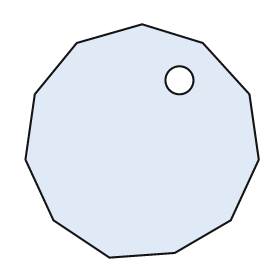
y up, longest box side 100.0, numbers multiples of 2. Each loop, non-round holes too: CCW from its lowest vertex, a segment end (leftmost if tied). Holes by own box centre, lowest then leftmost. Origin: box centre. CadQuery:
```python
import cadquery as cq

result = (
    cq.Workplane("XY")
    .moveTo(-14.0, -50.0)
    .lineTo(14.0, -48.0)
    .lineTo(38.0, -34.0)
    .lineTo(50.0, -8.0)
    .lineTo(46.0, 20.0)
    .lineTo(26.0, 42.0)
    .lineTo(0.0, 50.0)
    .lineTo(-28.0, 42.0)
    .lineTo(-46.0, 20.0)
    .lineTo(-50.0, -8.0)
    .lineTo(-38.0, -34.0)
    .close()
    .moveTo(16.0, 26.0)
    .circle(6.0)
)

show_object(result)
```